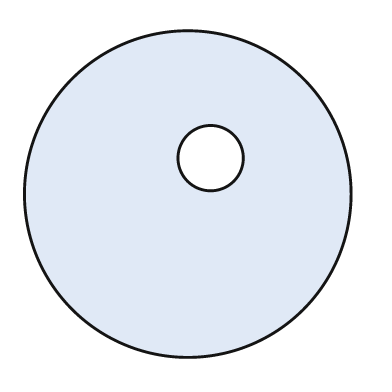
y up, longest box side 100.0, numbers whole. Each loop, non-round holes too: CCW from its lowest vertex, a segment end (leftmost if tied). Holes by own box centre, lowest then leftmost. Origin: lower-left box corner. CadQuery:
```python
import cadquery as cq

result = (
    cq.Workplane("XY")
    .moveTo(50.0, 50.0)
    .circle(50.0)
    .moveTo(57.0, 61.0)
    .circle(10.0)
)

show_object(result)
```